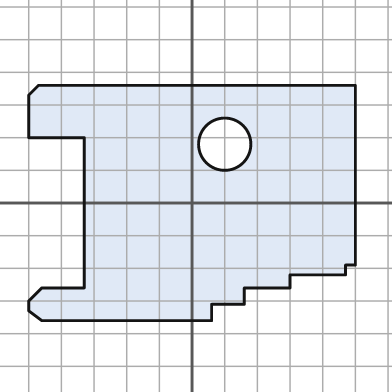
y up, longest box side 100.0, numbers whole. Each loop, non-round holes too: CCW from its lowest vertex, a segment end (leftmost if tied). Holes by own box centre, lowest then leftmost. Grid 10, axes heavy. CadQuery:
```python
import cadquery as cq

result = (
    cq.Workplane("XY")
    .moveTo(-46.0, -36.0)
    .lineTo(6.0, -36.0)
    .lineTo(6.0, -31.0)
    .lineTo(16.0, -31.0)
    .lineTo(16.0, -26.0)
    .lineTo(30.0, -26.0)
    .lineTo(30.0, -22.0)
    .lineTo(47.0, -22.0)
    .lineTo(47.0, -19.0)
    .lineTo(50.0, -19.0)
    .lineTo(50.0, 36.0)
    .lineTo(-47.0, 36.0)
    .lineTo(-50.0, 33.0)
    .lineTo(-50.0, 20.0)
    .lineTo(-33.0, 20.0)
    .lineTo(-33.0, -26.0)
    .lineTo(-46.0, -26.0)
    .lineTo(-50.0, -30.0)
    .lineTo(-50.0, -33.0)
    .close()
    .moveTo(10.0, 18.0)
    .circle(8.0)
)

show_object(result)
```